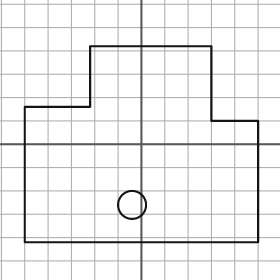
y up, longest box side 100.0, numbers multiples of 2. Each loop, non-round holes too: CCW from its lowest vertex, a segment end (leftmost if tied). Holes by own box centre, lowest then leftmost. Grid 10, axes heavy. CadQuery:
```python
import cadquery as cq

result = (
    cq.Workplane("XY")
    .moveTo(-50.0, -42.0)
    .lineTo(50.0, -42.0)
    .lineTo(50.0, 10.0)
    .lineTo(30.0, 10.0)
    .lineTo(30.0, 42.0)
    .lineTo(-22.0, 42.0)
    .lineTo(-22.0, 16.0)
    .lineTo(-50.0, 16.0)
    .close()
    .moveTo(-4.0, -26.0)
    .circle(6.0)
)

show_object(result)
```